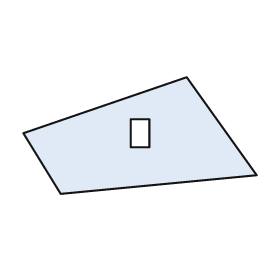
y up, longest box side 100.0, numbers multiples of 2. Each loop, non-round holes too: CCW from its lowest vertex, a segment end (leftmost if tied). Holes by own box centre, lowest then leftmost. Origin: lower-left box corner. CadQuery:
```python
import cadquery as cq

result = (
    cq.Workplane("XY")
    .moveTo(16.0, 0.0)
    .lineTo(100.0, 8.0)
    .lineTo(70.0, 50.0)
    .lineTo(0.0, 26.0)
    .close()
    .moveTo(46.0, 20.0)
    .lineTo(54.0, 20.0)
    .lineTo(54.0, 32.0)
    .lineTo(46.0, 32.0)
    .close()
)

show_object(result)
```